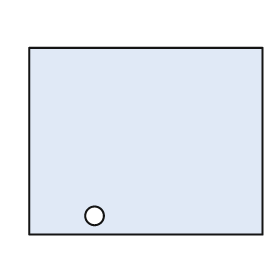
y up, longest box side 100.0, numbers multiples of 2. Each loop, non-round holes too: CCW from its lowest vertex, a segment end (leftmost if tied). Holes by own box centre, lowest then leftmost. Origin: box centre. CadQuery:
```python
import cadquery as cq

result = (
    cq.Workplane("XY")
    .moveTo(-50.0, -40.0)
    .lineTo(50.0, -40.0)
    .lineTo(50.0, 40.0)
    .lineTo(-50.0, 40.0)
    .close()
    .moveTo(-22.0, -32.0)
    .circle(4.0)
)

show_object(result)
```